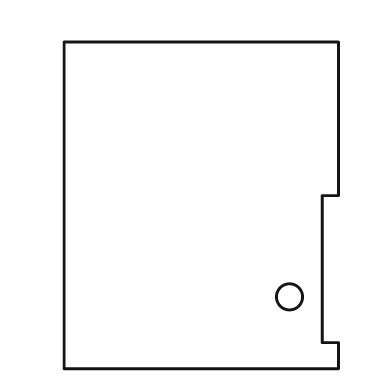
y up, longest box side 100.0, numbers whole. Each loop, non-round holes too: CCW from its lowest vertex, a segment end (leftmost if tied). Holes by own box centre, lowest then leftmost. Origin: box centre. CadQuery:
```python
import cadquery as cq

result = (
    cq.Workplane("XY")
    .moveTo(-42.0, -50.0)
    .lineTo(42.0, -50.0)
    .lineTo(42.0, -42.0)
    .lineTo(37.0, -42.0)
    .lineTo(37.0, 3.0)
    .lineTo(42.0, 3.0)
    .lineTo(42.0, 50.0)
    .lineTo(-42.0, 50.0)
    .close()
    .moveTo(27.0, -28.0)
    .circle(4.0)
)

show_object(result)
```